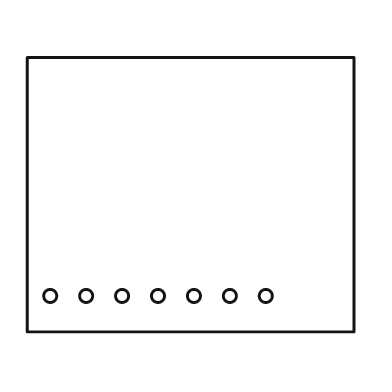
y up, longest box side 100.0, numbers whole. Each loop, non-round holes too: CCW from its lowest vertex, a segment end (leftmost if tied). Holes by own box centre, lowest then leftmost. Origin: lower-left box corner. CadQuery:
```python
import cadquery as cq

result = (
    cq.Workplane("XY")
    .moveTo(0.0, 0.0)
    .lineTo(100.0, 0.0)
    .lineTo(100.0, 84.0)
    .lineTo(0.0, 84.0)
    .close()
    .moveTo(7.0, 11.0)
    .circle(2.0)
    .moveTo(18.0, 11.0)
    .circle(2.0)
    .moveTo(29.0, 11.0)
    .circle(2.0)
    .moveTo(40.0, 11.0)
    .circle(2.0)
    .moveTo(51.0, 11.0)
    .circle(2.0)
    .moveTo(62.0, 11.0)
    .circle(2.0)
    .moveTo(73.0, 11.0)
    .circle(2.0)
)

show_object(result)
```